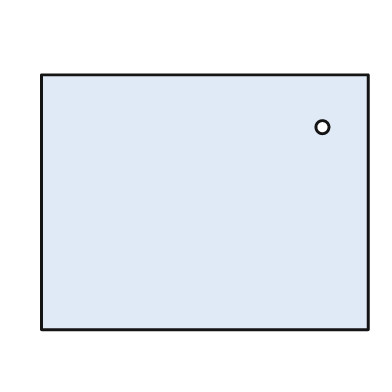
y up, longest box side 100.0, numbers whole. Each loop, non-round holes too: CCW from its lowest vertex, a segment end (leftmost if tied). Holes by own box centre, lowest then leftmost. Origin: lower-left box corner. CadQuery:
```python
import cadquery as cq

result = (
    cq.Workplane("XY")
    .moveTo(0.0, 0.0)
    .lineTo(100.0, 0.0)
    .lineTo(100.0, 78.0)
    .lineTo(0.0, 78.0)
    .close()
    .moveTo(86.0, 62.0)
    .circle(2.0)
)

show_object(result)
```